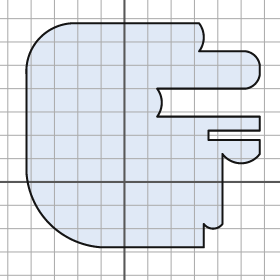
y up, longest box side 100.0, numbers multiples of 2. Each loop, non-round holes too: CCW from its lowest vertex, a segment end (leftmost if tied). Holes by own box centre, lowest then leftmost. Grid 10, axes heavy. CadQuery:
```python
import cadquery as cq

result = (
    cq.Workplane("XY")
    .moveTo(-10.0, -28.0)
    .lineTo(34.0, -28.0)
    .lineTo(34.0, -18.0)
    .threePointArc((38.0, -20.0), (42.0, -18.0))
    .lineTo(42.0, 12.0)
    .threePointArc((50.0, 8.0), (58.0, 12.0))
    .lineTo(58.0, 18.0)
    .lineTo(36.0, 18.0)
    .lineTo(36.0, 22.0)
    .lineTo(58.0, 22.0)
    .lineTo(58.0, 28.0)
    .lineTo(14.0, 28.0)
    .threePointArc((16.0, 34.0), (14.0, 40.0))
    .lineTo(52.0, 40.0)
    .threePointArc((56.0, 42.0), (58.0, 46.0))
    .lineTo(58.0, 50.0)
    .threePointArc((56.0, 54.0), (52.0, 56.0))
    .lineTo(32.0, 56.0)
    .threePointArc((34.0, 62.0), (32.0, 68.0))
    .lineTo(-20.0, 68.0)
    .threePointArc((-36.0, 62.0), (-42.0, 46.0))
    .lineTo(-42.0, 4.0)
    .threePointArc((-32.0, -18.0), (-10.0, -28.0))
    .close()
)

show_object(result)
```